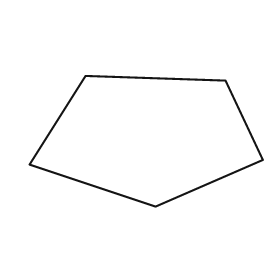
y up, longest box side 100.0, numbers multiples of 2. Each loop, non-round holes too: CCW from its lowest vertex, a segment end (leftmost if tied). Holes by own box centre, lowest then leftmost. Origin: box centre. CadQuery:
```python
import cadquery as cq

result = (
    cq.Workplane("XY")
    .moveTo(4.0, -28.0)
    .lineTo(50.0, -8.0)
    .lineTo(34.0, 26.0)
    .lineTo(-26.0, 28.0)
    .lineTo(-50.0, -10.0)
    .close()
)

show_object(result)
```